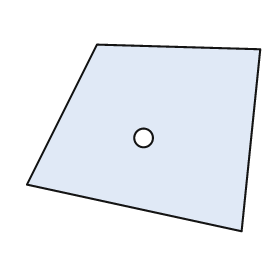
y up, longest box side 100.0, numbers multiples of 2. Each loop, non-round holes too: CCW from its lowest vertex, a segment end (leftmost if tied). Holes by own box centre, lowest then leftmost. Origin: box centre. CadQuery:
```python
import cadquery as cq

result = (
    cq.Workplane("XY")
    .moveTo(42.0, -40.0)
    .lineTo(50.0, 38.0)
    .lineTo(-20.0, 40.0)
    .lineTo(-50.0, -20.0)
    .close()
    .moveTo(0.0, 0.0)
    .circle(4.0)
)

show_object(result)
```